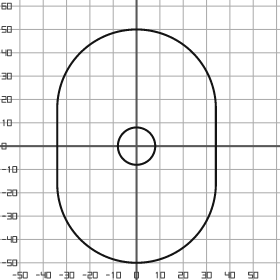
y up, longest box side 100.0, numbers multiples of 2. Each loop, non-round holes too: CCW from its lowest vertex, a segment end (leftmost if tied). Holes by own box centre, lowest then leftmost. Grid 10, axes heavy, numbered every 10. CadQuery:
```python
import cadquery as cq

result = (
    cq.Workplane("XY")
    .moveTo(-34.0, -16.0)
    .threePointArc((0.0, -50.0), (34.0, -16.0))
    .lineTo(34.0, 16.0)
    .threePointArc((0.0, 50.0), (-34.0, 16.0))
    .close()
    .moveTo(0.0, 0.0)
    .circle(8.0)
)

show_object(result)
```